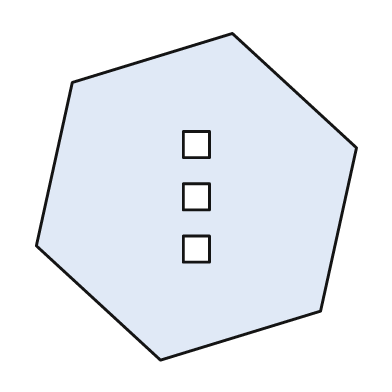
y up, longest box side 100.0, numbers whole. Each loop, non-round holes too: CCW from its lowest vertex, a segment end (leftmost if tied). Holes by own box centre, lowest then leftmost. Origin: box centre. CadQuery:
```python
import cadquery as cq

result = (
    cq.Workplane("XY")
    .moveTo(-11.0, -50.0)
    .lineTo(38.0, -35.0)
    .lineTo(49.0, 15.0)
    .lineTo(11.0, 50.0)
    .lineTo(-38.0, 35.0)
    .lineTo(-49.0, -15.0)
    .close()
    .moveTo(-4.0, -20.0)
    .lineTo(4.0, -20.0)
    .lineTo(4.0, -12.0)
    .lineTo(-4.0, -12.0)
    .close()
    .moveTo(-4.0, -4.0)
    .lineTo(4.0, -4.0)
    .lineTo(4.0, 4.0)
    .lineTo(-4.0, 4.0)
    .close()
    .moveTo(-4.0, 12.0)
    .lineTo(4.0, 12.0)
    .lineTo(4.0, 20.0)
    .lineTo(-4.0, 20.0)
    .close()
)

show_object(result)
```